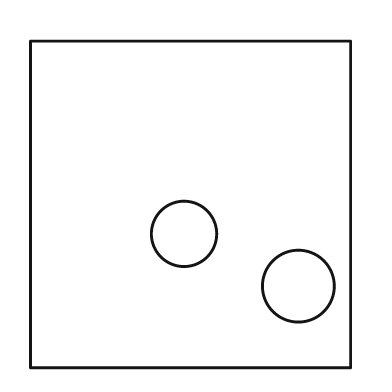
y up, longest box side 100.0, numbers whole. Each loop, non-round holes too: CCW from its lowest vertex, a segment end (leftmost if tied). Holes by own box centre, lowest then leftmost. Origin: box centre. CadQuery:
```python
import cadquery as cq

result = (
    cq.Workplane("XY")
    .moveTo(-49.0, -50.0)
    .lineTo(49.0, -50.0)
    .lineTo(49.0, 50.0)
    .lineTo(-49.0, 50.0)
    .close()
    .moveTo(33.0, -25.0)
    .circle(11.0)
    .moveTo(-2.0, -9.0)
    .circle(10.0)
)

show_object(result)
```